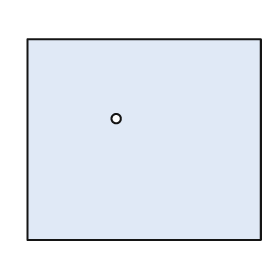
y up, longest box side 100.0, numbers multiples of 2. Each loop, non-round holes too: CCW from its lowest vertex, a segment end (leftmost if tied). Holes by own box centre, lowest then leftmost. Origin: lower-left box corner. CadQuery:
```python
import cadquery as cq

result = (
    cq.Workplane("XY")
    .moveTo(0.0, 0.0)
    .lineTo(100.0, 0.0)
    .lineTo(100.0, 86.0)
    .lineTo(0.0, 86.0)
    .close()
    .moveTo(38.0, 52.0)
    .circle(2.0)
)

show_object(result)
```